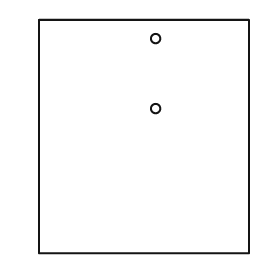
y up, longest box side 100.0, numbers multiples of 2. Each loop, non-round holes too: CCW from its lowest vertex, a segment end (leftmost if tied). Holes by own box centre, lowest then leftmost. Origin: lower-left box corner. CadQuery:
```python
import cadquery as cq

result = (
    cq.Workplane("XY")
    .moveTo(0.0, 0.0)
    .lineTo(90.0, 0.0)
    .lineTo(90.0, 100.0)
    .lineTo(0.0, 100.0)
    .close()
    .moveTo(50.0, 62.0)
    .circle(2.0)
    .moveTo(50.0, 92.0)
    .circle(2.0)
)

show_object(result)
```